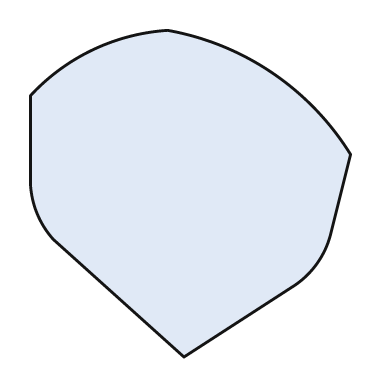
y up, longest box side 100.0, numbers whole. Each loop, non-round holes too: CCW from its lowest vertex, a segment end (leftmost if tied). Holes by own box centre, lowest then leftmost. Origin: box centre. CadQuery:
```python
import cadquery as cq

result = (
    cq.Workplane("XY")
    .moveTo(-2.0, -50.0)
    .lineTo(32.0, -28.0)
    .threePointArc((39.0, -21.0), (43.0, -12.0))
    .lineTo(49.0, 12.0)
    .threePointArc((25.0, 37.0), (-7.0, 50.0))
    .threePointArc((-30.0, 44.0), (-49.0, 30.0))
    .lineTo(-49.0, 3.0)
    .threePointArc((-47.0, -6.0), (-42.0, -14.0))
    .close()
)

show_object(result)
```